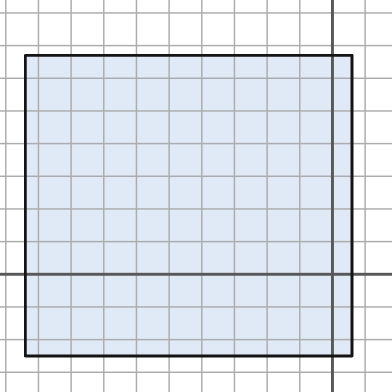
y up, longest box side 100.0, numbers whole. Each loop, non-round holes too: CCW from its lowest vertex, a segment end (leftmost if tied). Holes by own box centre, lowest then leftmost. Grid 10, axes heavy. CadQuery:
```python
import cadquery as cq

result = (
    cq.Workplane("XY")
    .moveTo(-94.0, -25.0)
    .lineTo(6.0, -25.0)
    .lineTo(6.0, 67.0)
    .lineTo(-94.0, 67.0)
    .close()
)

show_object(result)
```